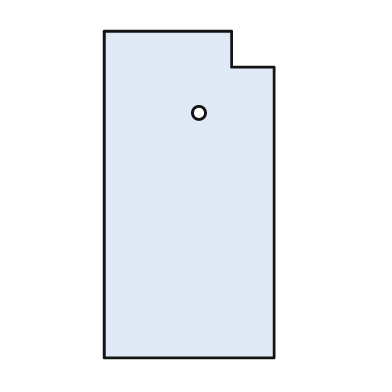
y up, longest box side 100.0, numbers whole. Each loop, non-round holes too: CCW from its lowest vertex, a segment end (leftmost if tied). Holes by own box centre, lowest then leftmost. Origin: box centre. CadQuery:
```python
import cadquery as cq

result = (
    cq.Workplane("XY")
    .moveTo(-26.0, -50.0)
    .lineTo(26.0, -50.0)
    .lineTo(26.0, 39.0)
    .lineTo(13.0, 39.0)
    .lineTo(13.0, 50.0)
    .lineTo(-26.0, 50.0)
    .close()
    .moveTo(3.0, 25.0)
    .circle(2.0)
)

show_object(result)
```